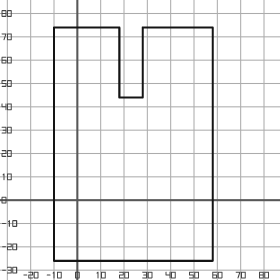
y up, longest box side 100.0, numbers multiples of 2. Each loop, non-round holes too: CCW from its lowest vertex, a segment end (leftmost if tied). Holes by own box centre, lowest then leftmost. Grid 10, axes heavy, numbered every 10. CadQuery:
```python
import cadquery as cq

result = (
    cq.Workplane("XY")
    .moveTo(-10.0, -26.0)
    .lineTo(58.0, -26.0)
    .lineTo(58.0, 74.0)
    .lineTo(28.0, 74.0)
    .lineTo(28.0, 44.0)
    .lineTo(18.0, 44.0)
    .lineTo(18.0, 74.0)
    .lineTo(-10.0, 74.0)
    .close()
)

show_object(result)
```